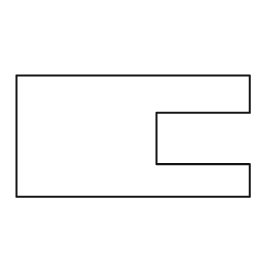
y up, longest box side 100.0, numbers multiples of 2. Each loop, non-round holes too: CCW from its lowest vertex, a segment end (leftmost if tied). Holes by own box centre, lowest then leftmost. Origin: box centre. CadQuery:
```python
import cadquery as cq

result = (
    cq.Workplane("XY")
    .moveTo(-50.0, -26.0)
    .lineTo(50.0, -26.0)
    .lineTo(50.0, -12.0)
    .lineTo(10.0, -12.0)
    .lineTo(10.0, 10.0)
    .lineTo(50.0, 10.0)
    .lineTo(50.0, 26.0)
    .lineTo(-50.0, 26.0)
    .close()
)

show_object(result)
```